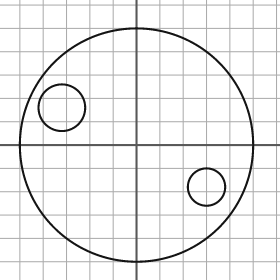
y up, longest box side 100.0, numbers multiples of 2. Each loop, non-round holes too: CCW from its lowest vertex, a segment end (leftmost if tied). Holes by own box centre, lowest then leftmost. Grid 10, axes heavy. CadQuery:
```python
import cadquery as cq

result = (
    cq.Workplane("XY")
    .moveTo(0.0, 0.0)
    .circle(50.0)
    .moveTo(30.0, -18.0)
    .circle(8.0)
    .moveTo(-32.0, 16.0)
    .circle(10.0)
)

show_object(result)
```